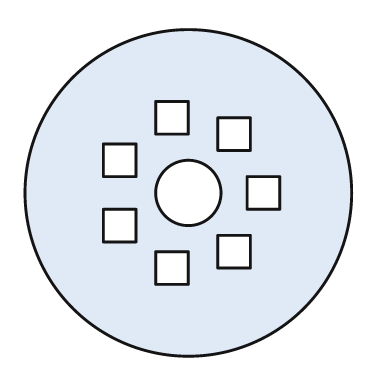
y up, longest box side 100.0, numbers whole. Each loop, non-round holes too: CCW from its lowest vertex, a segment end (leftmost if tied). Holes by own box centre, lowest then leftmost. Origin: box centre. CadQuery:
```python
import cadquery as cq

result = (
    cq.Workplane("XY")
    .moveTo(0.0, 0.0)
    .circle(50.0)
    .moveTo(-10.0, -28.0)
    .lineTo(0.0, -28.0)
    .lineTo(0.0, -18.0)
    .lineTo(-10.0, -18.0)
    .close()
    .moveTo(9.0, -23.0)
    .lineTo(19.0, -23.0)
    .lineTo(19.0, -13.0)
    .lineTo(9.0, -13.0)
    .close()
    .moveTo(-26.0, -15.0)
    .lineTo(-16.0, -15.0)
    .lineTo(-16.0, -5.0)
    .lineTo(-26.0, -5.0)
    .close()
    .moveTo(0.0, 0.0)
    .circle(10.0)
    .moveTo(18.0, -5.0)
    .lineTo(28.0, -5.0)
    .lineTo(28.0, 5.0)
    .lineTo(18.0, 5.0)
    .close()
    .moveTo(-26.0, 5.0)
    .lineTo(-16.0, 5.0)
    .lineTo(-16.0, 15.0)
    .lineTo(-26.0, 15.0)
    .close()
    .moveTo(9.0, 13.0)
    .lineTo(19.0, 13.0)
    .lineTo(19.0, 23.0)
    .lineTo(9.0, 23.0)
    .close()
    .moveTo(-10.0, 18.0)
    .lineTo(0.0, 18.0)
    .lineTo(0.0, 28.0)
    .lineTo(-10.0, 28.0)
    .close()
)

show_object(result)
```